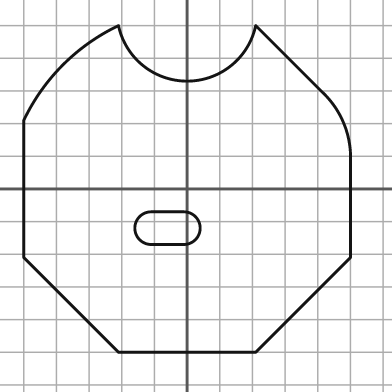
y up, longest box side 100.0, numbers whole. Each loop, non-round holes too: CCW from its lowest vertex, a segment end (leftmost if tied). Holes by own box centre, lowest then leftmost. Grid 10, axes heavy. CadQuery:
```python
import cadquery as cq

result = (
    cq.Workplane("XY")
    .moveTo(-21.0, -50.0)
    .lineTo(21.0, -50.0)
    .lineTo(50.0, -21.0)
    .lineTo(50.0, 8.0)
    .threePointArc((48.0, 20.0), (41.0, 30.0))
    .lineTo(21.0, 50.0)
    .threePointArc((0.0, 33.0), (-21.0, 50.0))
    .threePointArc((-38.0, 38.0), (-50.0, 21.0))
    .lineTo(-50.0, -21.0)
    .close()
    .moveTo(-11.0, -17.0)
    .lineTo(-1.0, -17.0)
    .threePointArc((4.0, -12.0), (-1.0, -7.0))
    .lineTo(-11.0, -7.0)
    .threePointArc((-16.0, -12.0), (-11.0, -17.0))
    .close()
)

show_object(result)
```